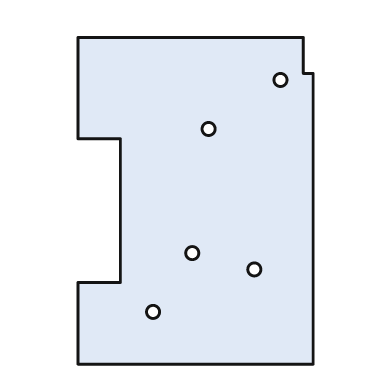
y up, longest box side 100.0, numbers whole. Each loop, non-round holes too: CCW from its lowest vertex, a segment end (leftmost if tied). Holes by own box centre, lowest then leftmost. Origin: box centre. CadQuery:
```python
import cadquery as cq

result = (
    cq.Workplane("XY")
    .moveTo(-36.0, -50.0)
    .lineTo(36.0, -50.0)
    .lineTo(36.0, 39.0)
    .lineTo(33.0, 39.0)
    .lineTo(33.0, 50.0)
    .lineTo(-36.0, 50.0)
    .lineTo(-36.0, 19.0)
    .lineTo(-23.0, 19.0)
    .lineTo(-23.0, -25.0)
    .lineTo(-36.0, -25.0)
    .close()
    .moveTo(-13.0, -34.0)
    .circle(2.0)
    .moveTo(18.0, -21.0)
    .circle(2.0)
    .moveTo(-1.0, -16.0)
    .circle(2.0)
    .moveTo(4.0, 22.0)
    .circle(2.0)
    .moveTo(26.0, 37.0)
    .circle(2.0)
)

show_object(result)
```